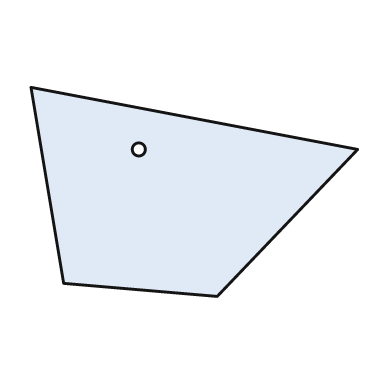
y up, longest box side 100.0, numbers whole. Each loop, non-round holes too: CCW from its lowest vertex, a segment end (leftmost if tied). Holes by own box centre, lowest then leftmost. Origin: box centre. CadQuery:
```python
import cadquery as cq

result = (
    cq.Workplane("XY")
    .moveTo(7.0, -32.0)
    .lineTo(50.0, 13.0)
    .lineTo(-50.0, 32.0)
    .lineTo(-40.0, -28.0)
    .close()
    .moveTo(-17.0, 13.0)
    .circle(2.0)
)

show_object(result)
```